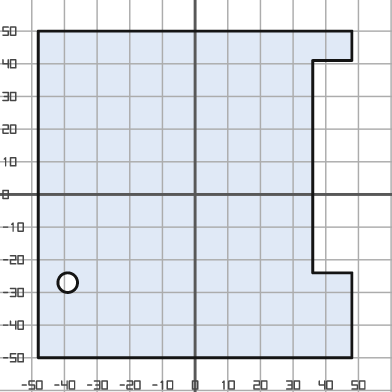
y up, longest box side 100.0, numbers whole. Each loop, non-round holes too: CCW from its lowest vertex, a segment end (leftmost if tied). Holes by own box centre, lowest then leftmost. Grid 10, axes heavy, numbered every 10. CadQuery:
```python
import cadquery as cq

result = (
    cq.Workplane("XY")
    .moveTo(-48.0, -50.0)
    .lineTo(48.0, -50.0)
    .lineTo(48.0, -24.0)
    .lineTo(36.0, -24.0)
    .lineTo(36.0, 41.0)
    .lineTo(48.0, 41.0)
    .lineTo(48.0, 50.0)
    .lineTo(-48.0, 50.0)
    .close()
    .moveTo(-39.0, -27.0)
    .circle(3.0)
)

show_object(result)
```